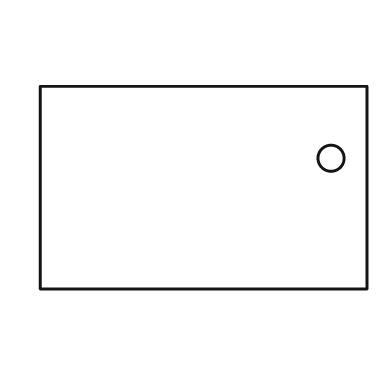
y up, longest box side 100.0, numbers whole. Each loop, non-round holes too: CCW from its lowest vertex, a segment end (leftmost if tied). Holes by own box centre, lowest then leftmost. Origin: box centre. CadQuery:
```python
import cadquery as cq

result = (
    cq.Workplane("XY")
    .moveTo(-50.0, -31.0)
    .lineTo(50.0, -31.0)
    .lineTo(50.0, 31.0)
    .lineTo(-50.0, 31.0)
    .close()
    .moveTo(39.0, 9.0)
    .circle(4.0)
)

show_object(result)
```